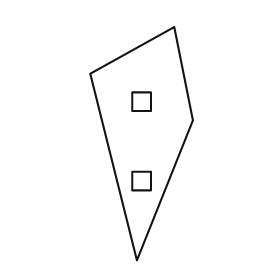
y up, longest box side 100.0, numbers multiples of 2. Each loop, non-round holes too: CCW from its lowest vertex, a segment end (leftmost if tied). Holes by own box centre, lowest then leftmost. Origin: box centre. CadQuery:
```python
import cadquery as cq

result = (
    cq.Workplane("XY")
    .moveTo(-2.0, -50.0)
    .lineTo(22.0, 10.0)
    .lineTo(14.0, 50.0)
    .lineTo(-22.0, 30.0)
    .close()
    .moveTo(-4.0, -20.0)
    .lineTo(4.0, -20.0)
    .lineTo(4.0, -12.0)
    .lineTo(-4.0, -12.0)
    .close()
    .moveTo(-4.0, 14.0)
    .lineTo(4.0, 14.0)
    .lineTo(4.0, 22.0)
    .lineTo(-4.0, 22.0)
    .close()
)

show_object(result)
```